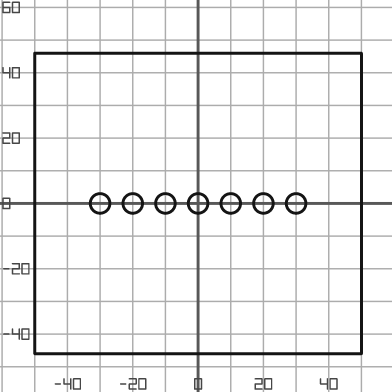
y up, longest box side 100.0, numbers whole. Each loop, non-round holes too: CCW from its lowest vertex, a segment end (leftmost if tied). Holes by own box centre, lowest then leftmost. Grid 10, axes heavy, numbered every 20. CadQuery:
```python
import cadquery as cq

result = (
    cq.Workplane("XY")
    .moveTo(-50.0, -46.0)
    .lineTo(50.0, -46.0)
    .lineTo(50.0, 46.0)
    .lineTo(-50.0, 46.0)
    .close()
    .moveTo(-30.0, 0.0)
    .circle(3.0)
    .moveTo(-20.0, 0.0)
    .circle(3.0)
    .moveTo(-10.0, 0.0)
    .circle(3.0)
    .moveTo(0.0, 0.0)
    .circle(3.0)
    .moveTo(10.0, 0.0)
    .circle(3.0)
    .moveTo(20.0, 0.0)
    .circle(3.0)
    .moveTo(30.0, 0.0)
    .circle(3.0)
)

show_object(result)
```